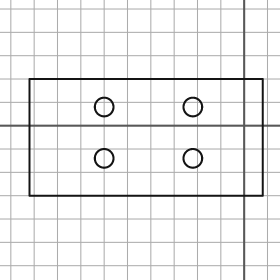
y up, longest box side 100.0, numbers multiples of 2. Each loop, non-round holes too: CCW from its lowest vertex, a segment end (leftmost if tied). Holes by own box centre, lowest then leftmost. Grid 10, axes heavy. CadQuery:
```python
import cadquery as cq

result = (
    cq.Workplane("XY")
    .moveTo(-92.0, -30.0)
    .lineTo(8.0, -30.0)
    .lineTo(8.0, 20.0)
    .lineTo(-92.0, 20.0)
    .close()
    .moveTo(-60.0, -14.0)
    .circle(4.0)
    .moveTo(-22.0, -14.0)
    .circle(4.0)
    .moveTo(-60.0, 8.0)
    .circle(4.0)
    .moveTo(-22.0, 8.0)
    .circle(4.0)
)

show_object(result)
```